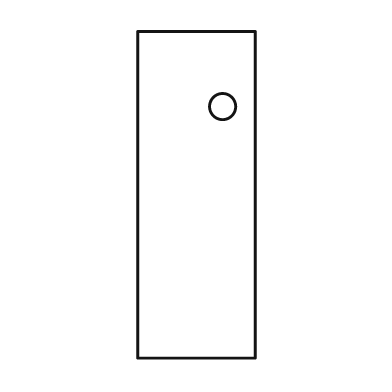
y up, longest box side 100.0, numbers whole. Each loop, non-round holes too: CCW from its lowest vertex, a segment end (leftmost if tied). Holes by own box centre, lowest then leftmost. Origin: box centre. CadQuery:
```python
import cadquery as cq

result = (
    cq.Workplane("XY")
    .moveTo(-18.0, -50.0)
    .lineTo(18.0, -50.0)
    .lineTo(18.0, 50.0)
    .lineTo(-18.0, 50.0)
    .close()
    .moveTo(8.0, 27.0)
    .circle(4.0)
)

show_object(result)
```